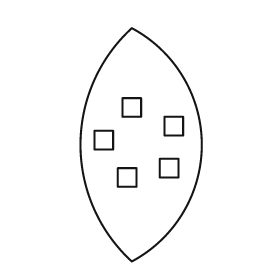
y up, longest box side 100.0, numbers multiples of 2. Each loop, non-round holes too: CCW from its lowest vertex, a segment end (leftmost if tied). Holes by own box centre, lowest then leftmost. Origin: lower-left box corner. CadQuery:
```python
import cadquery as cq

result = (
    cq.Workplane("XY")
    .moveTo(22.0, 0.0)
    .threePointArc((52.0, 50.0), (22.0, 100.0))
    .threePointArc((0.0, 50.0), (22.0, 0.0))
    .close()
    .moveTo(16.0, 32.0)
    .lineTo(24.0, 32.0)
    .lineTo(24.0, 40.0)
    .lineTo(16.0, 40.0)
    .close()
    .moveTo(34.0, 36.0)
    .lineTo(42.0, 36.0)
    .lineTo(42.0, 44.0)
    .lineTo(34.0, 44.0)
    .close()
    .moveTo(6.0, 48.0)
    .lineTo(14.0, 48.0)
    .lineTo(14.0, 56.0)
    .lineTo(6.0, 56.0)
    .close()
    .moveTo(36.0, 54.0)
    .lineTo(44.0, 54.0)
    .lineTo(44.0, 62.0)
    .lineTo(36.0, 62.0)
    .close()
    .moveTo(18.0, 62.0)
    .lineTo(26.0, 62.0)
    .lineTo(26.0, 70.0)
    .lineTo(18.0, 70.0)
    .close()
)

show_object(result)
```